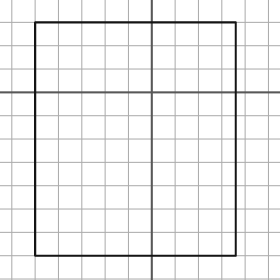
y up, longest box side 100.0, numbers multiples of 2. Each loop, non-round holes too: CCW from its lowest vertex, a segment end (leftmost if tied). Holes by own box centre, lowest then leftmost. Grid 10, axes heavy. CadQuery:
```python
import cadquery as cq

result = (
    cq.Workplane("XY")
    .moveTo(-50.0, -70.0)
    .lineTo(36.0, -70.0)
    .lineTo(36.0, 30.0)
    .lineTo(-50.0, 30.0)
    .close()
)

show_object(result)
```